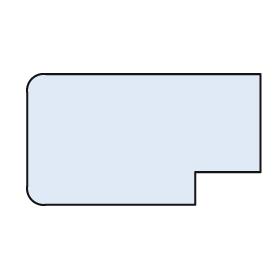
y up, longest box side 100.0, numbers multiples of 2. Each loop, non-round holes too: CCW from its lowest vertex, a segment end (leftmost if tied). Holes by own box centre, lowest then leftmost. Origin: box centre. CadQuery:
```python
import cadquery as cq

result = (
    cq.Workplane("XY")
    .moveTo(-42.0, -28.0)
    .lineTo(22.0, -28.0)
    .lineTo(22.0, -14.0)
    .lineTo(50.0, -14.0)
    .lineTo(50.0, 28.0)
    .lineTo(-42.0, 28.0)
    .threePointArc((-48.0, 26.0), (-50.0, 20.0))
    .lineTo(-50.0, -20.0)
    .threePointArc((-48.0, -26.0), (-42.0, -28.0))
    .close()
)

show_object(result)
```